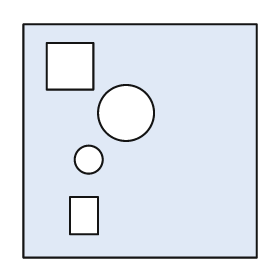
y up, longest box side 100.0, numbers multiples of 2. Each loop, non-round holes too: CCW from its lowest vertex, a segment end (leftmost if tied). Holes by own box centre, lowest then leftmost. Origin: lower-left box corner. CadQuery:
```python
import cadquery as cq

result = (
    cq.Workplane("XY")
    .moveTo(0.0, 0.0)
    .lineTo(100.0, 0.0)
    .lineTo(100.0, 100.0)
    .lineTo(0.0, 100.0)
    .close()
    .moveTo(20.0, 10.0)
    .lineTo(32.0, 10.0)
    .lineTo(32.0, 26.0)
    .lineTo(20.0, 26.0)
    .close()
    .moveTo(28.0, 42.0)
    .circle(6.0)
    .moveTo(44.0, 62.0)
    .circle(12.0)
    .moveTo(10.0, 72.0)
    .lineTo(30.0, 72.0)
    .lineTo(30.0, 92.0)
    .lineTo(10.0, 92.0)
    .close()
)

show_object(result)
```